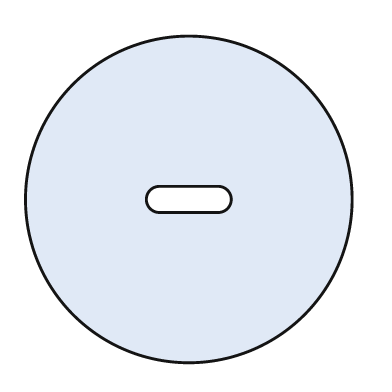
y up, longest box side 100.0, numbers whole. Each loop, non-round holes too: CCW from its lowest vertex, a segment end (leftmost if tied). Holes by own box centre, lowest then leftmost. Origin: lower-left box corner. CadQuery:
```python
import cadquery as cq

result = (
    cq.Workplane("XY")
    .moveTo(50.0, 50.0)
    .circle(50.0)
    .moveTo(41.0, 46.0)
    .lineTo(59.0, 46.0)
    .threePointArc((63.0, 50.0), (59.0, 54.0))
    .lineTo(41.0, 54.0)
    .threePointArc((37.0, 50.0), (41.0, 46.0))
    .close()
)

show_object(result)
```